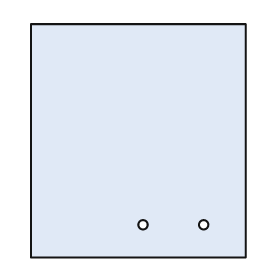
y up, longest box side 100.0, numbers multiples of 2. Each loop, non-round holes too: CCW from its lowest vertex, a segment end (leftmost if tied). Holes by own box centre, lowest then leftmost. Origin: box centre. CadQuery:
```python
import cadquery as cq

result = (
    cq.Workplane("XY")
    .moveTo(-46.0, -50.0)
    .lineTo(46.0, -50.0)
    .lineTo(46.0, 50.0)
    .lineTo(-46.0, 50.0)
    .close()
    .moveTo(2.0, -36.0)
    .circle(2.0)
    .moveTo(28.0, -36.0)
    .circle(2.0)
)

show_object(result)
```